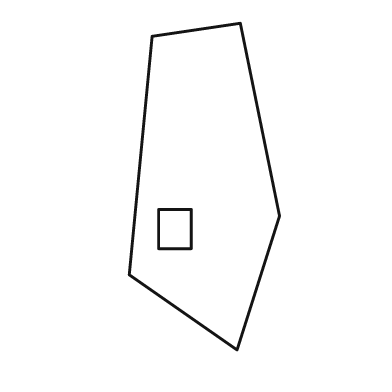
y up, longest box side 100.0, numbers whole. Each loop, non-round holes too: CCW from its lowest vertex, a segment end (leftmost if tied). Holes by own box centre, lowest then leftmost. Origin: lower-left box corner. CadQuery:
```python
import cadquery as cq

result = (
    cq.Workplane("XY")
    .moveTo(33.0, 0.0)
    .lineTo(46.0, 41.0)
    .lineTo(34.0, 100.0)
    .lineTo(7.0, 96.0)
    .lineTo(0.0, 23.0)
    .close()
    .moveTo(9.0, 31.0)
    .lineTo(19.0, 31.0)
    .lineTo(19.0, 43.0)
    .lineTo(9.0, 43.0)
    .close()
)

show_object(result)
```